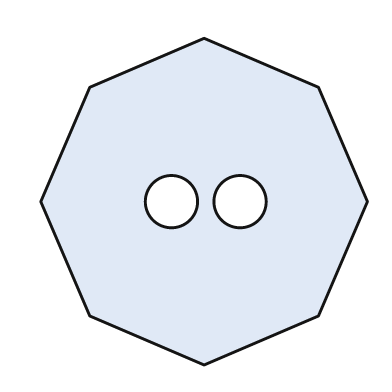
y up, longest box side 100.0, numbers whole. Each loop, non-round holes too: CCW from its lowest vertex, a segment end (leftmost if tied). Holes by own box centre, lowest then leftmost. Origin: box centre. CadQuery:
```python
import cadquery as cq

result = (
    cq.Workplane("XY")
    .moveTo(0.0, -50.0)
    .lineTo(35.0, -35.0)
    .lineTo(50.0, 0.0)
    .lineTo(35.0, 35.0)
    .lineTo(0.0, 50.0)
    .lineTo(-35.0, 35.0)
    .lineTo(-50.0, 0.0)
    .lineTo(-35.0, -35.0)
    .close()
    .moveTo(-10.0, 0.0)
    .circle(8.0)
    .moveTo(11.0, 0.0)
    .circle(8.0)
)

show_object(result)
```